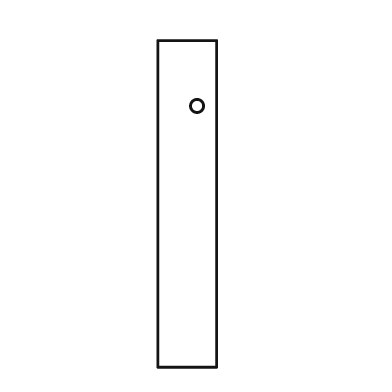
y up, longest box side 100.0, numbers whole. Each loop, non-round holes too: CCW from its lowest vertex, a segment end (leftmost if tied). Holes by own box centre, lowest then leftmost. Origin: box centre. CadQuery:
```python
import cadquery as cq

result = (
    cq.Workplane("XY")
    .moveTo(-9.0, -50.0)
    .lineTo(9.0, -50.0)
    .lineTo(9.0, 50.0)
    .lineTo(-9.0, 50.0)
    .close()
    .moveTo(3.0, 30.0)
    .circle(2.0)
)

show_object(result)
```